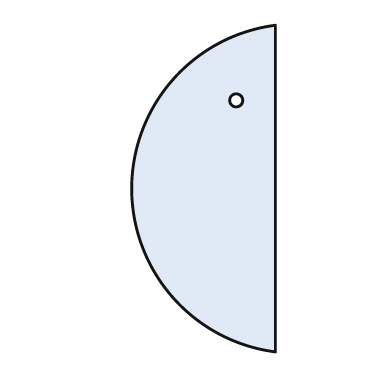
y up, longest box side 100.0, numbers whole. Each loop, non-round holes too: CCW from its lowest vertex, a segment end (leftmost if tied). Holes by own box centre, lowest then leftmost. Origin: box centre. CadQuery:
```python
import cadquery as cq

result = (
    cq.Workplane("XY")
    .moveTo(22.0, -50.0)
    .lineTo(22.0, 50.0)
    .threePointArc((-22.0, 0.0), (22.0, -50.0))
    .close()
    .moveTo(10.0, 27.0)
    .circle(2.0)
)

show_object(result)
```